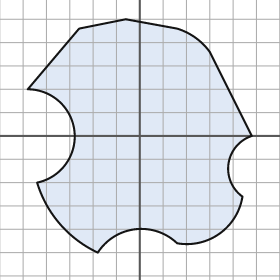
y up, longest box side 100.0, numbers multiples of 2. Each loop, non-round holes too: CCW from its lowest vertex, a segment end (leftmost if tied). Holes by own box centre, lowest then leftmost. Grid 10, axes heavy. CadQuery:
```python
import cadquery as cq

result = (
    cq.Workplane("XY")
    .moveTo(-18.0, -50.0)
    .threePointArc((-2.0, -40.0), (16.0, -46.0))
    .threePointArc((34.0, -42.0), (44.0, -26.0))
    .threePointArc((38.0, -12.0), (48.0, 0.0))
    .lineTo(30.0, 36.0)
    .threePointArc((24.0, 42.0), (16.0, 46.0))
    .lineTo(-6.0, 50.0)
    .lineTo(-26.0, 46.0)
    .lineTo(-48.0, 20.0)
    .threePointArc((-28.0, 2.0), (-44.0, -20.0))
    .threePointArc((-34.0, -38.0), (-18.0, -50.0))
    .close()
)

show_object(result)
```